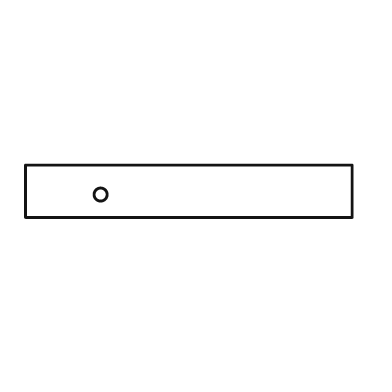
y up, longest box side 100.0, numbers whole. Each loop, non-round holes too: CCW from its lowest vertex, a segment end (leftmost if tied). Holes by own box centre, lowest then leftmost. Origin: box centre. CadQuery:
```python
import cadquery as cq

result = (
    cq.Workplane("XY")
    .moveTo(-50.0, -8.0)
    .lineTo(50.0, -8.0)
    .lineTo(50.0, 8.0)
    .lineTo(-50.0, 8.0)
    .close()
    .moveTo(-27.0, -1.0)
    .circle(2.0)
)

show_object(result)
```